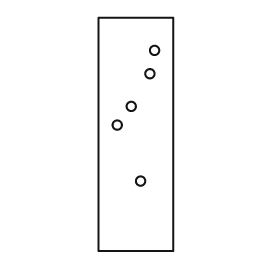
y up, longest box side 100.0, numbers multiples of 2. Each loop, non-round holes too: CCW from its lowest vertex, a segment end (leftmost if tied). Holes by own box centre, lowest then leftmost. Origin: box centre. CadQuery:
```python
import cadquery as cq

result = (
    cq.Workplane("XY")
    .moveTo(-16.0, -50.0)
    .lineTo(16.0, -50.0)
    .lineTo(16.0, 50.0)
    .lineTo(-16.0, 50.0)
    .close()
    .moveTo(2.0, -20.0)
    .circle(2.0)
    .moveTo(-8.0, 4.0)
    .circle(2.0)
    .moveTo(-2.0, 12.0)
    .circle(2.0)
    .moveTo(6.0, 26.0)
    .circle(2.0)
    .moveTo(8.0, 36.0)
    .circle(2.0)
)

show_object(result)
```